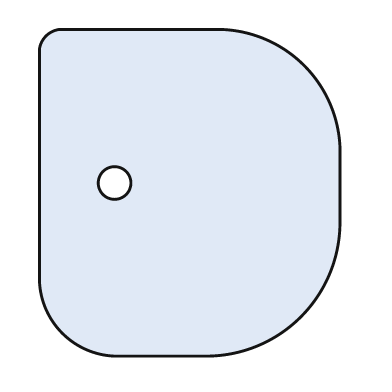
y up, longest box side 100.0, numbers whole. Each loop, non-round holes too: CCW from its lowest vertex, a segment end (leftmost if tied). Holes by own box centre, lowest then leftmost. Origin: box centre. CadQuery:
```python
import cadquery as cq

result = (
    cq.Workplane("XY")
    .moveTo(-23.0, -50.0)
    .lineTo(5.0, -50.0)
    .threePointArc((34.0, -38.0), (46.0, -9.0))
    .lineTo(46.0, 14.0)
    .threePointArc((35.0, 39.0), (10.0, 50.0))
    .lineTo(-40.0, 50.0)
    .threePointArc((-44.0, 48.0), (-46.0, 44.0))
    .lineTo(-46.0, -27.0)
    .threePointArc((-39.0, -43.0), (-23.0, -50.0))
    .close()
    .moveTo(-23.0, 3.0)
    .circle(5.0)
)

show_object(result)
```